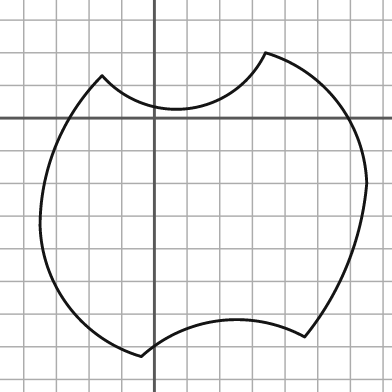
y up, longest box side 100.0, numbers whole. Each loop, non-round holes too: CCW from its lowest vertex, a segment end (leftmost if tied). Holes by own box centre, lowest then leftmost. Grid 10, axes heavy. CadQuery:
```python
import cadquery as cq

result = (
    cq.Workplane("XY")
    .moveTo(-4.0, -73.0)
    .threePointArc((20.0, -62.0), (46.0, -67.0))
    .threePointArc((59.0, -45.0), (65.0, -20.0))
    .threePointArc((56.0, 5.0), (34.0, 20.0))
    .threePointArc((11.0, 3.0), (-16.0, 13.0))
    .threePointArc((-30.0, -8.0), (-35.0, -33.0))
    .threePointArc((-26.0, -58.0), (-4.0, -73.0))
    .close()
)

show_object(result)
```